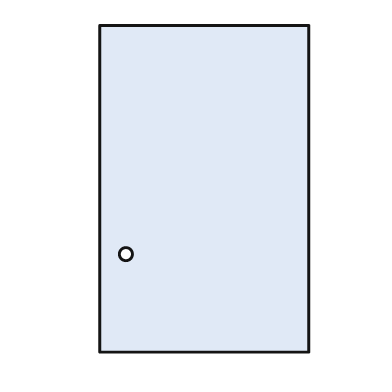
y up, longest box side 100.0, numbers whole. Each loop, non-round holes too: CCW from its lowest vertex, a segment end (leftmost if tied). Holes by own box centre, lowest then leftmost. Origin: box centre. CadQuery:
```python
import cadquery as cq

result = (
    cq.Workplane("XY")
    .moveTo(-32.0, -50.0)
    .lineTo(32.0, -50.0)
    .lineTo(32.0, 50.0)
    .lineTo(-32.0, 50.0)
    .close()
    .moveTo(-24.0, -20.0)
    .circle(2.0)
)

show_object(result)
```